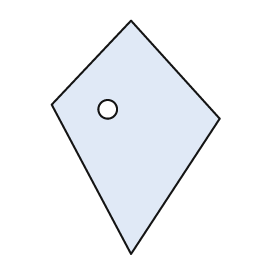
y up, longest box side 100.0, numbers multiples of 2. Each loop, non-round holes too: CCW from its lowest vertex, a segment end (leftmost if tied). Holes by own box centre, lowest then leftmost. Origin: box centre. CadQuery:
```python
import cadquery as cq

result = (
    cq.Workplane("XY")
    .moveTo(-2.0, -50.0)
    .lineTo(36.0, 8.0)
    .lineTo(-2.0, 50.0)
    .lineTo(-36.0, 14.0)
    .close()
    .moveTo(-12.0, 12.0)
    .circle(4.0)
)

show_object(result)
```